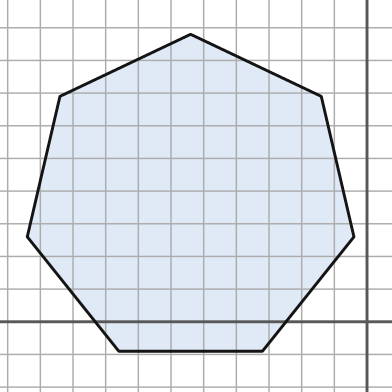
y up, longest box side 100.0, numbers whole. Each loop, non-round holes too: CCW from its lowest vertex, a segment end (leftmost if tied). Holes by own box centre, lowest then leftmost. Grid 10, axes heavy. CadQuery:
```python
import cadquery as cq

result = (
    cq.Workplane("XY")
    .moveTo(-76.0, -9.0)
    .lineTo(-32.0, -9.0)
    .lineTo(-4.0, 26.0)
    .lineTo(-14.0, 69.0)
    .lineTo(-54.0, 88.0)
    .lineTo(-94.0, 69.0)
    .lineTo(-104.0, 26.0)
    .close()
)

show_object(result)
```